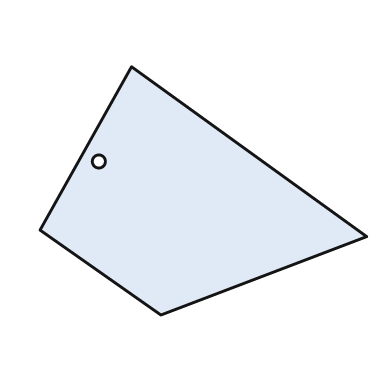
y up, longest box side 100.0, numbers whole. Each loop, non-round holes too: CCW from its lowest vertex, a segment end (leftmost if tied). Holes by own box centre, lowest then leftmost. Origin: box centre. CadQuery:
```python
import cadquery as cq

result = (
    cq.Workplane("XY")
    .moveTo(-13.0, -38.0)
    .lineTo(50.0, -14.0)
    .lineTo(-22.0, 38.0)
    .lineTo(-50.0, -12.0)
    .close()
    .moveTo(-32.0, 9.0)
    .circle(2.0)
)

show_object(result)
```